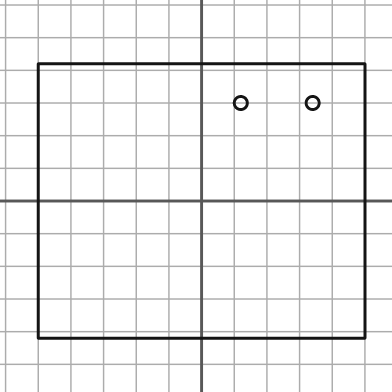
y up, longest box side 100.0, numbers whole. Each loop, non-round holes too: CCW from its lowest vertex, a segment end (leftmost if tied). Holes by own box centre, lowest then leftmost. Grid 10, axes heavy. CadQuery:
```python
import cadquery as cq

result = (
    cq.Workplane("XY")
    .moveTo(-50.0, -42.0)
    .lineTo(50.0, -42.0)
    .lineTo(50.0, 42.0)
    .lineTo(-50.0, 42.0)
    .close()
    .moveTo(12.0, 30.0)
    .circle(2.0)
    .moveTo(34.0, 30.0)
    .circle(2.0)
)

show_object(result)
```